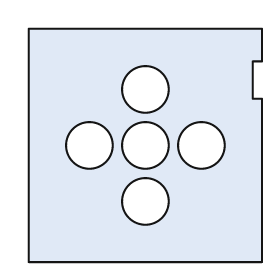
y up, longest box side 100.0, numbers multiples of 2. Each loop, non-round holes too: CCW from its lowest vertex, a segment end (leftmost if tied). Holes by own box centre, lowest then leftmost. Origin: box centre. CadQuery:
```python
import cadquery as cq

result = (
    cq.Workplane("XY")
    .moveTo(-50.0, -50.0)
    .lineTo(50.0, -50.0)
    .lineTo(50.0, 20.0)
    .lineTo(46.0, 20.0)
    .lineTo(46.0, 36.0)
    .lineTo(50.0, 36.0)
    .lineTo(50.0, 50.0)
    .lineTo(-50.0, 50.0)
    .close()
    .moveTo(0.0, -24.0)
    .circle(10.0)
    .moveTo(-24.0, 0.0)
    .circle(10.0)
    .moveTo(0.0, 0.0)
    .circle(10.0)
    .moveTo(24.0, 0.0)
    .circle(10.0)
    .moveTo(0.0, 24.0)
    .circle(10.0)
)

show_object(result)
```